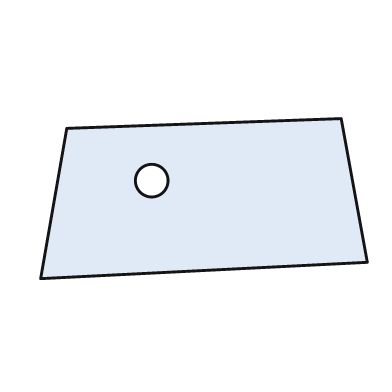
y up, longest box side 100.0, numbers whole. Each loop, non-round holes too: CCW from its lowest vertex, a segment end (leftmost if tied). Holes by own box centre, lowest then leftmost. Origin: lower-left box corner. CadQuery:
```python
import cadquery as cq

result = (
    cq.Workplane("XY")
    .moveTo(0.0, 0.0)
    .lineTo(100.0, 5.0)
    .lineTo(92.0, 49.0)
    .lineTo(8.0, 46.0)
    .close()
    .moveTo(34.0, 30.0)
    .circle(5.0)
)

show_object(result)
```